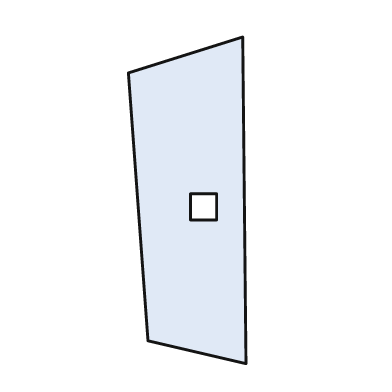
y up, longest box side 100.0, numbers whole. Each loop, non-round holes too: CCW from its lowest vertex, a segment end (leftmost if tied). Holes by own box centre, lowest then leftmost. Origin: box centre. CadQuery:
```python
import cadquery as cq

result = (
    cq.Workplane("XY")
    .moveTo(18.0, -50.0)
    .lineTo(17.0, 50.0)
    .lineTo(-18.0, 39.0)
    .lineTo(-12.0, -43.0)
    .close()
    .moveTo(1.0, -6.0)
    .lineTo(9.0, -6.0)
    .lineTo(9.0, 2.0)
    .lineTo(1.0, 2.0)
    .close()
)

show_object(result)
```